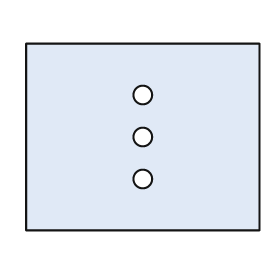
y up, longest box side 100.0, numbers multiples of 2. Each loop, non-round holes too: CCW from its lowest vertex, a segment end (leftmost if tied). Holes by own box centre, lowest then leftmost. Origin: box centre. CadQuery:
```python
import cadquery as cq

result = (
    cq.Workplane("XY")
    .moveTo(-50.0, -40.0)
    .lineTo(50.0, -40.0)
    .lineTo(50.0, 40.0)
    .lineTo(-50.0, 40.0)
    .close()
    .moveTo(0.0, -18.0)
    .circle(4.0)
    .moveTo(0.0, 0.0)
    .circle(4.0)
    .moveTo(0.0, 18.0)
    .circle(4.0)
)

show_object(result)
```